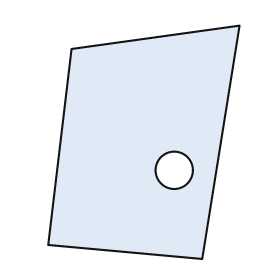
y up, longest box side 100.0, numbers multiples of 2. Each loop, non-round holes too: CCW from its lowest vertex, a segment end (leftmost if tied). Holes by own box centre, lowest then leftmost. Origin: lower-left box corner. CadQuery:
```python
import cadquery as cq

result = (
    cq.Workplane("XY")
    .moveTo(66.0, 0.0)
    .lineTo(82.0, 100.0)
    .lineTo(10.0, 90.0)
    .lineTo(0.0, 6.0)
    .close()
    .moveTo(54.0, 38.0)
    .circle(8.0)
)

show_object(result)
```